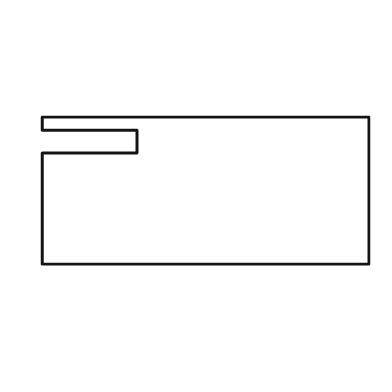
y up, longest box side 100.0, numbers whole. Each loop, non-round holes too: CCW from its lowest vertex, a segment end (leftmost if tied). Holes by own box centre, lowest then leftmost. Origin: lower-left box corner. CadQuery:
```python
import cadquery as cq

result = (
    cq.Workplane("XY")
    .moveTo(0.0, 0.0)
    .lineTo(100.0, 0.0)
    .lineTo(100.0, 45.0)
    .lineTo(0.0, 45.0)
    .lineTo(0.0, 41.0)
    .lineTo(29.0, 41.0)
    .lineTo(29.0, 34.0)
    .lineTo(0.0, 34.0)
    .close()
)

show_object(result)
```